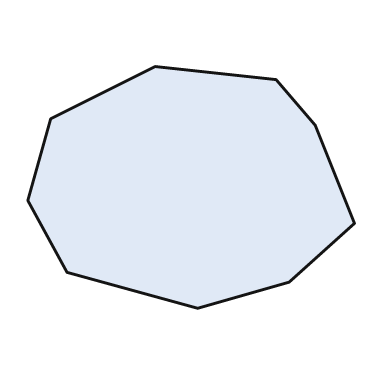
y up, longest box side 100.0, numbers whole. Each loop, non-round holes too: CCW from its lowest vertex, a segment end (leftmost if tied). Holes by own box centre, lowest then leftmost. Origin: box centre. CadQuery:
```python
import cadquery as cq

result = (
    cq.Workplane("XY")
    .moveTo(2.0, -37.0)
    .lineTo(30.0, -29.0)
    .lineTo(50.0, -11.0)
    .lineTo(38.0, 19.0)
    .lineTo(26.0, 33.0)
    .lineTo(-11.0, 37.0)
    .lineTo(-43.0, 21.0)
    .lineTo(-50.0, -4.0)
    .lineTo(-38.0, -26.0)
    .close()
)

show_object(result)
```